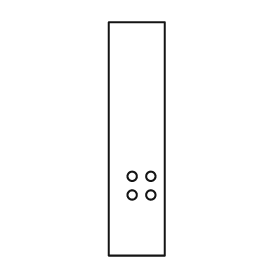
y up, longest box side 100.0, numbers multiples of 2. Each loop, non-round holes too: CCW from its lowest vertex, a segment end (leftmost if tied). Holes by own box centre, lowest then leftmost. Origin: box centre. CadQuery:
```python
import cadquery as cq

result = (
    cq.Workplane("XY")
    .moveTo(-12.0, -50.0)
    .lineTo(12.0, -50.0)
    .lineTo(12.0, 50.0)
    .lineTo(-12.0, 50.0)
    .close()
    .moveTo(-2.0, -24.0)
    .circle(2.0)
    .moveTo(6.0, -24.0)
    .circle(2.0)
    .moveTo(-2.0, -16.0)
    .circle(2.0)
    .moveTo(6.0, -16.0)
    .circle(2.0)
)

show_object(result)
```